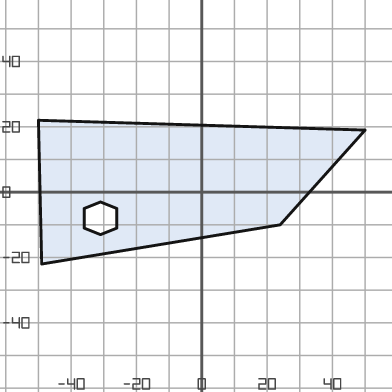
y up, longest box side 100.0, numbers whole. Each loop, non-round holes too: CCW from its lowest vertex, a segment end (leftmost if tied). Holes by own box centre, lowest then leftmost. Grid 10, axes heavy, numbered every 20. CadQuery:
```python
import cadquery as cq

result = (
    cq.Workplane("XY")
    .moveTo(-49.0, -22.0)
    .lineTo(24.0, -10.0)
    .lineTo(50.0, 19.0)
    .lineTo(-50.0, 22.0)
    .close()
    .moveTo(-31.0, -13.0)
    .lineTo(-26.0, -11.0)
    .lineTo(-26.0, -5.0)
    .lineTo(-31.0, -3.0)
    .lineTo(-36.0, -5.0)
    .lineTo(-36.0, -11.0)
    .close()
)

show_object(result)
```